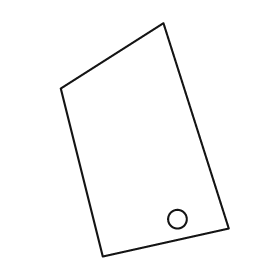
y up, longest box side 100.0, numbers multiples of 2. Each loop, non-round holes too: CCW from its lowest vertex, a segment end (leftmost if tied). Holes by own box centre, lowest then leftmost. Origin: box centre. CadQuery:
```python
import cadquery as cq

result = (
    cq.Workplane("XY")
    .moveTo(-18.0, -50.0)
    .lineTo(36.0, -38.0)
    .lineTo(8.0, 50.0)
    .lineTo(-36.0, 22.0)
    .close()
    .moveTo(14.0, -34.0)
    .circle(4.0)
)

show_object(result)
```